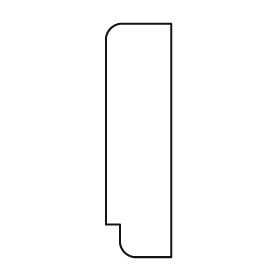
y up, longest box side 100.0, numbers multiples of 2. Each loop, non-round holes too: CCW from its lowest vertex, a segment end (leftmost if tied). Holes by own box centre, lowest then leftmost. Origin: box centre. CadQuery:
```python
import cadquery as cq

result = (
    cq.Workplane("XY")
    .moveTo(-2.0, -50.0)
    .lineTo(14.0, -50.0)
    .lineTo(14.0, 50.0)
    .lineTo(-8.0, 50.0)
    .threePointArc((-12.0, 48.0), (-14.0, 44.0))
    .lineTo(-14.0, -36.0)
    .lineTo(-8.0, -36.0)
    .lineTo(-8.0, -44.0)
    .threePointArc((-6.0, -48.0), (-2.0, -50.0))
    .close()
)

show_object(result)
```